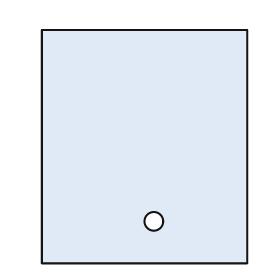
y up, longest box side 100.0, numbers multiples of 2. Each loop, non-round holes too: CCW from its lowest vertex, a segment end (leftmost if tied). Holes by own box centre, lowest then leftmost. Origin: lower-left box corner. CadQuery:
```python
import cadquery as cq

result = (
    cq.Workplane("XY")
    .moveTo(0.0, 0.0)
    .lineTo(88.0, 0.0)
    .lineTo(88.0, 100.0)
    .lineTo(0.0, 100.0)
    .close()
    .moveTo(48.0, 18.0)
    .circle(4.0)
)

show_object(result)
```